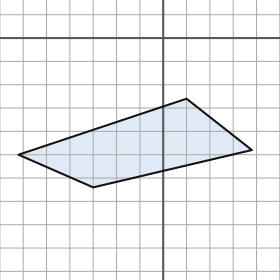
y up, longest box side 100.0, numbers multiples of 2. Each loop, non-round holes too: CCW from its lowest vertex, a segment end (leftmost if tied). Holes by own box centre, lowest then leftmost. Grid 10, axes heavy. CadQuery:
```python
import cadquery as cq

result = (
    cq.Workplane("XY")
    .moveTo(-30.0, -64.0)
    .lineTo(38.0, -48.0)
    .lineTo(10.0, -26.0)
    .lineTo(-62.0, -50.0)
    .close()
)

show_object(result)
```